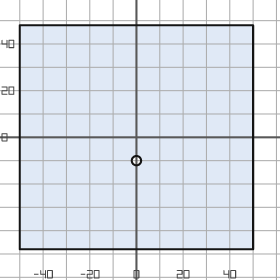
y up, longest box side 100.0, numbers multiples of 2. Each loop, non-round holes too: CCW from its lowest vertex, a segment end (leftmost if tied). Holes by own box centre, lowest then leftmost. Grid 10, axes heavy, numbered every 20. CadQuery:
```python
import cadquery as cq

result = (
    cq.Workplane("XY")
    .moveTo(-50.0, -48.0)
    .lineTo(50.0, -48.0)
    .lineTo(50.0, 48.0)
    .lineTo(-50.0, 48.0)
    .close()
    .moveTo(0.0, -10.0)
    .circle(2.0)
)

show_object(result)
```